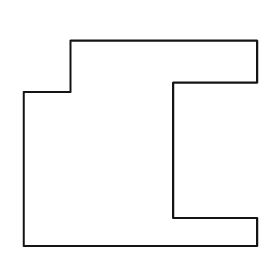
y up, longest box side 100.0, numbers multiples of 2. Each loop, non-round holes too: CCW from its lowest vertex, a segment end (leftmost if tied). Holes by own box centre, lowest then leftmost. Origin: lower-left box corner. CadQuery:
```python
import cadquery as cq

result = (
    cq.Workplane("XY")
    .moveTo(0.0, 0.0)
    .lineTo(100.0, 0.0)
    .lineTo(100.0, 12.0)
    .lineTo(64.0, 12.0)
    .lineTo(64.0, 70.0)
    .lineTo(100.0, 70.0)
    .lineTo(100.0, 88.0)
    .lineTo(20.0, 88.0)
    .lineTo(20.0, 66.0)
    .lineTo(0.0, 66.0)
    .close()
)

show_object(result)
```